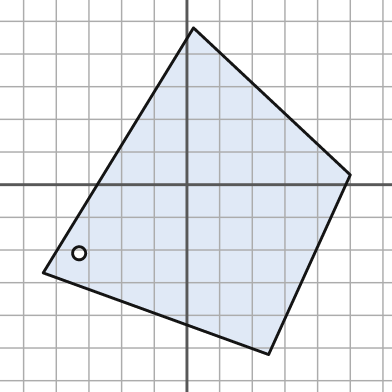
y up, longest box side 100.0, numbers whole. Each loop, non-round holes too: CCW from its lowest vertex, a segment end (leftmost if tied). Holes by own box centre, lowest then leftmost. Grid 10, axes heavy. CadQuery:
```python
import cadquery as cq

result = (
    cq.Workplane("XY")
    .moveTo(25.0, -52.0)
    .lineTo(50.0, 3.0)
    .lineTo(2.0, 48.0)
    .lineTo(-44.0, -27.0)
    .close()
    .moveTo(-33.0, -21.0)
    .circle(2.0)
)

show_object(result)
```